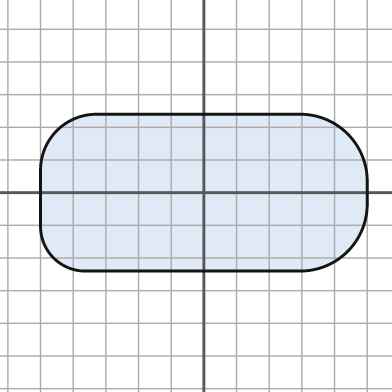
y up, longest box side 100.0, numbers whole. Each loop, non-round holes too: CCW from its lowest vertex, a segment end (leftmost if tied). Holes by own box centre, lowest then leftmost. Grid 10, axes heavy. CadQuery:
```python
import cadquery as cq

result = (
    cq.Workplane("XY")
    .moveTo(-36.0, -24.0)
    .lineTo(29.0, -24.0)
    .threePointArc((44.0, -18.0), (50.0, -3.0))
    .lineTo(50.0, 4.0)
    .threePointArc((44.0, 18.0), (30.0, 24.0))
    .lineTo(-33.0, 24.0)
    .threePointArc((-45.0, 19.0), (-50.0, 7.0))
    .lineTo(-50.0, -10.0)
    .threePointArc((-46.0, -20.0), (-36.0, -24.0))
    .close()
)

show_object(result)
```